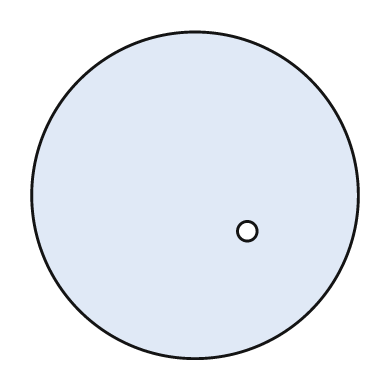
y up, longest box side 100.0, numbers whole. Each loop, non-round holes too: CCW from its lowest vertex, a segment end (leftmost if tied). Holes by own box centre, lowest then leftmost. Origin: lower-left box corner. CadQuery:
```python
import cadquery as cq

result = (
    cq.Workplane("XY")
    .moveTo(50.0, 50.0)
    .circle(50.0)
    .moveTo(66.0, 39.0)
    .circle(3.0)
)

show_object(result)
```